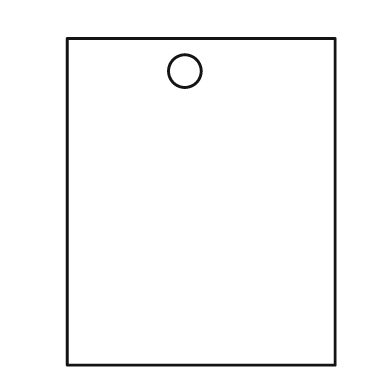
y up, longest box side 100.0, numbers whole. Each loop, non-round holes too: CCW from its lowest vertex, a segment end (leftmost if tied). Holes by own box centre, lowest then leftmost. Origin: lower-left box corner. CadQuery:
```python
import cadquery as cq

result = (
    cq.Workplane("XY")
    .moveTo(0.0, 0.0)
    .lineTo(82.0, 0.0)
    .lineTo(82.0, 100.0)
    .lineTo(0.0, 100.0)
    .close()
    .moveTo(36.0, 90.0)
    .circle(5.0)
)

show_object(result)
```